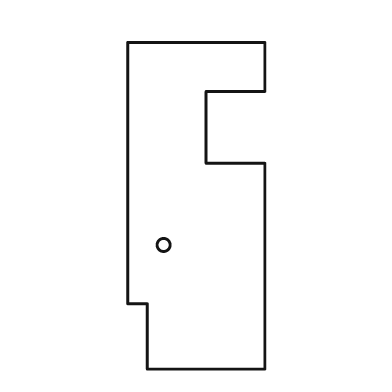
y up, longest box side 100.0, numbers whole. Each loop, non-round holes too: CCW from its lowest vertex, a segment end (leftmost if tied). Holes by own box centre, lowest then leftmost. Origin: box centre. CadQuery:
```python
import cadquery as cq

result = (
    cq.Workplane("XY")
    .moveTo(-15.0, -50.0)
    .lineTo(21.0, -50.0)
    .lineTo(21.0, 13.0)
    .lineTo(3.0, 13.0)
    .lineTo(3.0, 35.0)
    .lineTo(21.0, 35.0)
    .lineTo(21.0, 50.0)
    .lineTo(-21.0, 50.0)
    .lineTo(-21.0, -30.0)
    .lineTo(-15.0, -30.0)
    .close()
    .moveTo(-10.0, -12.0)
    .circle(2.0)
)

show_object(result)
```